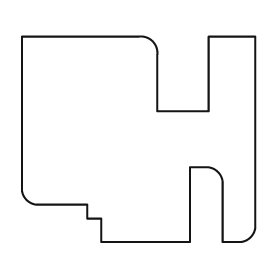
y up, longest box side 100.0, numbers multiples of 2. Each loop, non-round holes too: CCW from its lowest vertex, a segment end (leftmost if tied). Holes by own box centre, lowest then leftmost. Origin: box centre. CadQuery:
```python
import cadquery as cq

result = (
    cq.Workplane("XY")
    .moveTo(-16.0, -44.0)
    .lineTo(22.0, -44.0)
    .lineTo(22.0, -12.0)
    .lineTo(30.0, -12.0)
    .threePointArc((34.0, -14.0), (36.0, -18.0))
    .lineTo(36.0, -44.0)
    .lineTo(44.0, -44.0)
    .threePointArc((48.0, -42.0), (50.0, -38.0))
    .lineTo(50.0, 44.0)
    .lineTo(30.0, 44.0)
    .lineTo(30.0, 12.0)
    .lineTo(8.0, 12.0)
    .lineTo(8.0, 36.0)
    .threePointArc((6.0, 42.0), (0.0, 44.0))
    .lineTo(-50.0, 44.0)
    .lineTo(-50.0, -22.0)
    .threePointArc((-48.0, -26.0), (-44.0, -28.0))
    .lineTo(-22.0, -28.0)
    .lineTo(-22.0, -34.0)
    .lineTo(-16.0, -34.0)
    .close()
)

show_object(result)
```